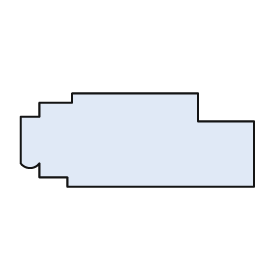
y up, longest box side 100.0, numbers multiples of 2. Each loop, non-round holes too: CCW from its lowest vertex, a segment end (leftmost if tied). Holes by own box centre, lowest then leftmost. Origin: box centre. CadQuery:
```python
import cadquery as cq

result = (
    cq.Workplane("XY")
    .moveTo(-30.0, -20.0)
    .lineTo(50.0, -20.0)
    .lineTo(50.0, 8.0)
    .lineTo(26.0, 8.0)
    .lineTo(26.0, 20.0)
    .lineTo(-28.0, 20.0)
    .lineTo(-28.0, 16.0)
    .lineTo(-42.0, 16.0)
    .lineTo(-42.0, 10.0)
    .lineTo(-50.0, 10.0)
    .lineTo(-50.0, -10.0)
    .threePointArc((-46.0, -12.0), (-42.0, -10.0))
    .lineTo(-42.0, -16.0)
    .lineTo(-30.0, -16.0)
    .close()
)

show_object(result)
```